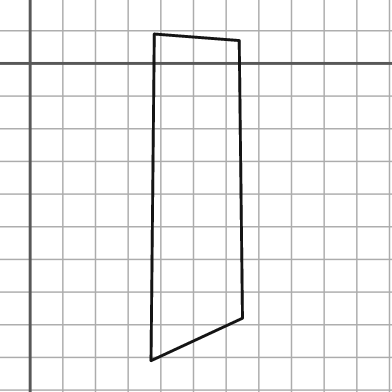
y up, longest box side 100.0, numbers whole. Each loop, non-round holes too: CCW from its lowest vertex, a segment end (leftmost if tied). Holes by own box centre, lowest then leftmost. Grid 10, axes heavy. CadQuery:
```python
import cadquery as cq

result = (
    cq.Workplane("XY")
    .moveTo(37.0, -91.0)
    .lineTo(65.0, -78.0)
    .lineTo(64.0, 7.0)
    .lineTo(38.0, 9.0)
    .close()
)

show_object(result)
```